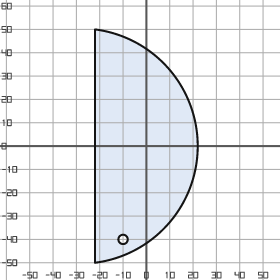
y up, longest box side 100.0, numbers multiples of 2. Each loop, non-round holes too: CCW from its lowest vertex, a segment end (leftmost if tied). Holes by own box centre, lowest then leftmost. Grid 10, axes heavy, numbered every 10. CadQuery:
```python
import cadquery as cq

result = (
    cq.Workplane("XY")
    .moveTo(-22.0, -50.0)
    .threePointArc((22.0, 0.0), (-22.0, 50.0))
    .close()
    .moveTo(-10.0, -40.0)
    .circle(2.0)
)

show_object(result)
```